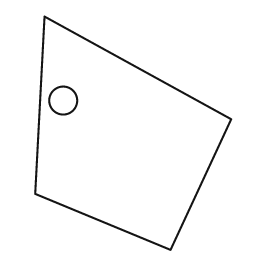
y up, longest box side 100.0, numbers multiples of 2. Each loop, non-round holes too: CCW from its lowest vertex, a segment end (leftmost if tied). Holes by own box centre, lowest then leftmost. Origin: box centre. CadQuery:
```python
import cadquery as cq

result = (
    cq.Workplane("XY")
    .moveTo(16.0, -50.0)
    .lineTo(42.0, 6.0)
    .lineTo(-38.0, 50.0)
    .lineTo(-42.0, -26.0)
    .close()
    .moveTo(-30.0, 14.0)
    .circle(6.0)
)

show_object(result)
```